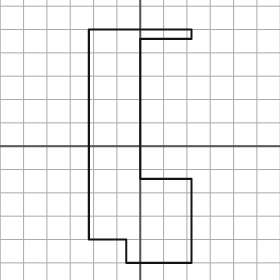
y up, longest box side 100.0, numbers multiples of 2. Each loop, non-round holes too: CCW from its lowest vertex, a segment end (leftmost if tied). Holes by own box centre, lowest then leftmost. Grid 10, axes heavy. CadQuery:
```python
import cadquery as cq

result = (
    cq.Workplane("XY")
    .moveTo(-6.0, -50.0)
    .lineTo(22.0, -50.0)
    .lineTo(22.0, -14.0)
    .lineTo(0.0, -14.0)
    .lineTo(0.0, 46.0)
    .lineTo(22.0, 46.0)
    .lineTo(22.0, 50.0)
    .lineTo(-22.0, 50.0)
    .lineTo(-22.0, -40.0)
    .lineTo(-6.0, -40.0)
    .close()
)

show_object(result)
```